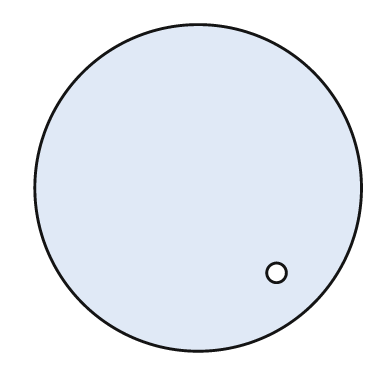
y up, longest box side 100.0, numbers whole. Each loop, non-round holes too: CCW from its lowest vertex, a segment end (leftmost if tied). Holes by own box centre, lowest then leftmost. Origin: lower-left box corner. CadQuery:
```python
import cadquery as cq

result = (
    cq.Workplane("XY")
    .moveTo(50.0, 50.0)
    .circle(50.0)
    .moveTo(74.0, 24.0)
    .circle(3.0)
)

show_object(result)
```